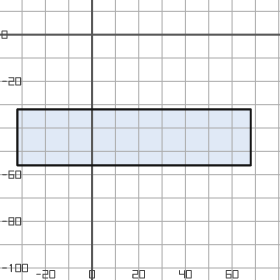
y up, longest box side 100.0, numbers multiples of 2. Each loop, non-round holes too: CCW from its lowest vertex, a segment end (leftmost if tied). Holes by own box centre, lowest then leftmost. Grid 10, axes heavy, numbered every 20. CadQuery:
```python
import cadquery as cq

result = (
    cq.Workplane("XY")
    .moveTo(-32.0, -56.0)
    .lineTo(68.0, -56.0)
    .lineTo(68.0, -32.0)
    .lineTo(-32.0, -32.0)
    .close()
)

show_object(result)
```